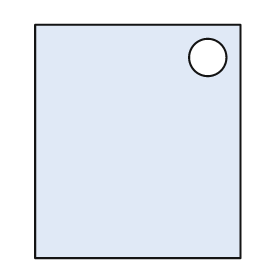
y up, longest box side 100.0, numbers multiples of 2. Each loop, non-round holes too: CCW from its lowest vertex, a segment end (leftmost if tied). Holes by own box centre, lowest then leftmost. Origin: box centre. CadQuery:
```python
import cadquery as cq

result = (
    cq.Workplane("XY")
    .moveTo(-44.0, -50.0)
    .lineTo(44.0, -50.0)
    .lineTo(44.0, 50.0)
    .lineTo(-44.0, 50.0)
    .close()
    .moveTo(30.0, 36.0)
    .circle(8.0)
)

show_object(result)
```